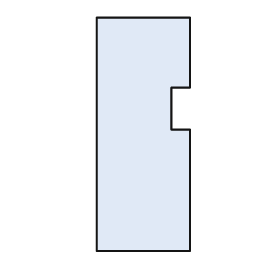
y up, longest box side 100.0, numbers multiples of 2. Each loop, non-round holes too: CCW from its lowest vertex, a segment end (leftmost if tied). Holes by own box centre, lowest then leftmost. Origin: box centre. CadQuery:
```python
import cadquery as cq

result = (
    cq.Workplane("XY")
    .moveTo(-20.0, -50.0)
    .lineTo(20.0, -50.0)
    .lineTo(20.0, 2.0)
    .lineTo(12.0, 2.0)
    .lineTo(12.0, 20.0)
    .lineTo(20.0, 20.0)
    .lineTo(20.0, 50.0)
    .lineTo(-20.0, 50.0)
    .close()
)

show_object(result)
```